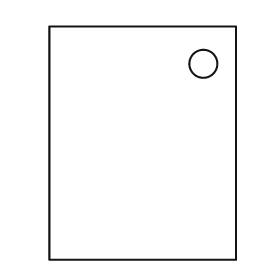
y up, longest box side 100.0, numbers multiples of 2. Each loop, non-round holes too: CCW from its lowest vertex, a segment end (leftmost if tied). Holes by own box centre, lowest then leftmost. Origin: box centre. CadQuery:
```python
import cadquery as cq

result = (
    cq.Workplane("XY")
    .moveTo(-40.0, -50.0)
    .lineTo(40.0, -50.0)
    .lineTo(40.0, 50.0)
    .lineTo(-40.0, 50.0)
    .close()
    .moveTo(26.0, 34.0)
    .circle(6.0)
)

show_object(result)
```